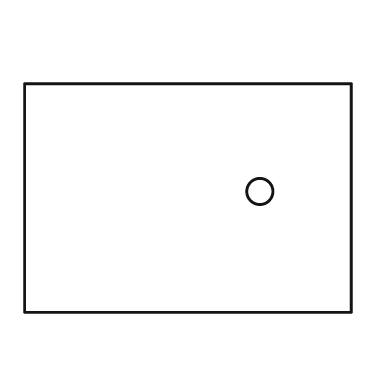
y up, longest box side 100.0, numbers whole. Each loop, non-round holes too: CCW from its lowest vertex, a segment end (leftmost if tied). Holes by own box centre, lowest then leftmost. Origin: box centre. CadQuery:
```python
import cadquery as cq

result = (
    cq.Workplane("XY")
    .moveTo(-50.0, -35.0)
    .lineTo(50.0, -35.0)
    .lineTo(50.0, 35.0)
    .lineTo(-50.0, 35.0)
    .close()
    .moveTo(22.0, 2.0)
    .circle(4.0)
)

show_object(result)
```